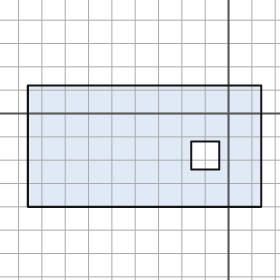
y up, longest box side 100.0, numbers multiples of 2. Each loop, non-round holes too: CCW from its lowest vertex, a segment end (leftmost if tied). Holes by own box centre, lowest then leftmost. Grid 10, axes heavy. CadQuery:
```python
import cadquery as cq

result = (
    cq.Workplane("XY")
    .moveTo(-86.0, -40.0)
    .lineTo(14.0, -40.0)
    .lineTo(14.0, 12.0)
    .lineTo(-86.0, 12.0)
    .close()
    .moveTo(-16.0, -24.0)
    .lineTo(-4.0, -24.0)
    .lineTo(-4.0, -12.0)
    .lineTo(-16.0, -12.0)
    .close()
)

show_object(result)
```